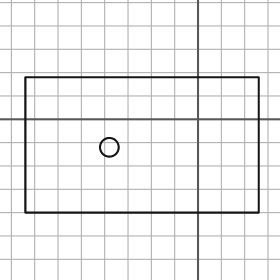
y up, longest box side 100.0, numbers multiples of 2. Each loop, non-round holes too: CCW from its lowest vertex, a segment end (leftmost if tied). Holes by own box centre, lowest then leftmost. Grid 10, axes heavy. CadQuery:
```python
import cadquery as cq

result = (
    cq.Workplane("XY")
    .moveTo(-74.0, -40.0)
    .lineTo(26.0, -40.0)
    .lineTo(26.0, 18.0)
    .lineTo(-74.0, 18.0)
    .close()
    .moveTo(-38.0, -12.0)
    .circle(4.0)
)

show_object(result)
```